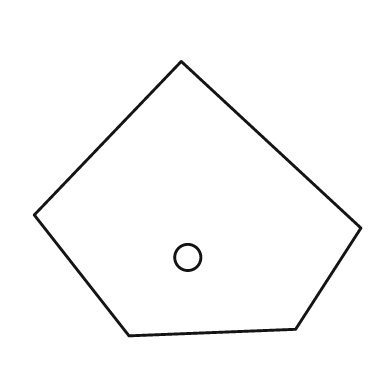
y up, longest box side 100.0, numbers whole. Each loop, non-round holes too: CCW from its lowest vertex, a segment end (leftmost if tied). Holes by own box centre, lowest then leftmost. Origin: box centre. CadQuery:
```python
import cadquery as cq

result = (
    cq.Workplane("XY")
    .moveTo(-21.0, -42.0)
    .lineTo(30.0, -40.0)
    .lineTo(50.0, -9.0)
    .lineTo(-5.0, 42.0)
    .lineTo(-50.0, -5.0)
    .close()
    .moveTo(-3.0, -18.0)
    .circle(4.0)
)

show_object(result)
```